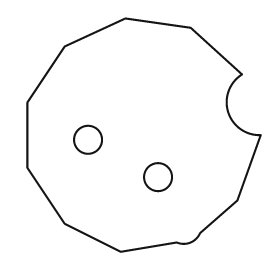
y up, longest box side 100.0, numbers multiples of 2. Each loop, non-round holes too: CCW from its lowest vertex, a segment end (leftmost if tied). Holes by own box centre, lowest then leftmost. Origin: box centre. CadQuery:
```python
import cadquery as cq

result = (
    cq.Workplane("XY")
    .moveTo(-10.0, -50.0)
    .lineTo(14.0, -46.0)
    .threePointArc((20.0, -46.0), (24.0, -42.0))
    .lineTo(40.0, -28.0)
    .lineTo(50.0, 0.0)
    .threePointArc((36.0, 10.0), (42.0, 26.0))
    .lineTo(20.0, 46.0)
    .lineTo(-8.0, 50.0)
    .lineTo(-34.0, 38.0)
    .lineTo(-50.0, 14.0)
    .lineTo(-50.0, -14.0)
    .lineTo(-34.0, -38.0)
    .close()
    .moveTo(6.0, -18.0)
    .circle(6.0)
    .moveTo(-24.0, -2.0)
    .circle(6.0)
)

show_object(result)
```